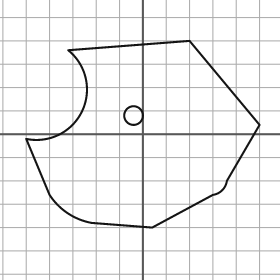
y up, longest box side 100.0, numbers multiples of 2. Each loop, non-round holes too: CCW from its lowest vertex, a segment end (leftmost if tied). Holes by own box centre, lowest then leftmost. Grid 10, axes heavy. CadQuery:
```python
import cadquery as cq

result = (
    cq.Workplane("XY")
    .moveTo(4.0, -40.0)
    .lineTo(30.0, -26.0)
    .threePointArc((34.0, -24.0), (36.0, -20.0))
    .lineTo(50.0, 4.0)
    .lineTo(20.0, 40.0)
    .lineTo(-32.0, 36.0)
    .threePointArc((-26.0, 10.0), (-50.0, -2.0))
    .lineTo(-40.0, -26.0)
    .threePointArc((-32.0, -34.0), (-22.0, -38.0))
    .close()
    .moveTo(-4.0, 8.0)
    .circle(4.0)
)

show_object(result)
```